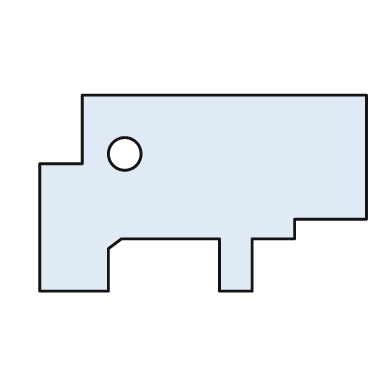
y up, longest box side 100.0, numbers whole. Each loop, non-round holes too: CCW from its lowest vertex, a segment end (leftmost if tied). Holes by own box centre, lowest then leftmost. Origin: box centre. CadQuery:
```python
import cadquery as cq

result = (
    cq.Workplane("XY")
    .moveTo(-50.0, -30.0)
    .lineTo(-29.0, -30.0)
    .lineTo(-29.0, -17.0)
    .lineTo(-25.0, -14.0)
    .lineTo(5.0, -14.0)
    .lineTo(5.0, -30.0)
    .lineTo(15.0, -30.0)
    .lineTo(15.0, -14.0)
    .lineTo(28.0, -14.0)
    .lineTo(28.0, -8.0)
    .lineTo(50.0, -8.0)
    .lineTo(50.0, 30.0)
    .lineTo(-37.0, 30.0)
    .lineTo(-37.0, 9.0)
    .lineTo(-50.0, 9.0)
    .close()
    .moveTo(-24.0, 12.0)
    .circle(5.0)
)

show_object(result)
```